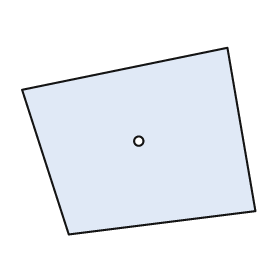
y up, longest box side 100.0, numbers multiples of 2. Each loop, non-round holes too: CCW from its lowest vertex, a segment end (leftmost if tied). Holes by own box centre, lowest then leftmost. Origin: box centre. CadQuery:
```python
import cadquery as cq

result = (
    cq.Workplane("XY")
    .moveTo(-30.0, -40.0)
    .lineTo(50.0, -30.0)
    .lineTo(38.0, 40.0)
    .lineTo(-50.0, 22.0)
    .close()
    .moveTo(0.0, 0.0)
    .circle(2.0)
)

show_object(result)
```